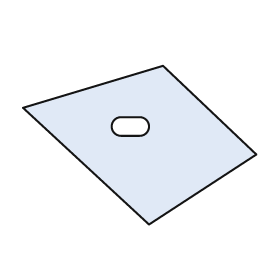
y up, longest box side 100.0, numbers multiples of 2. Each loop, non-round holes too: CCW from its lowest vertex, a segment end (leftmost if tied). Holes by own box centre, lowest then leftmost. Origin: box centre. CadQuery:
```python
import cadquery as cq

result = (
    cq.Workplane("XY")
    .moveTo(4.0, -34.0)
    .lineTo(50.0, -4.0)
    .lineTo(10.0, 34.0)
    .lineTo(-50.0, 16.0)
    .close()
    .moveTo(-8.0, 4.0)
    .lineTo(0.0, 4.0)
    .threePointArc((4.0, 8.0), (0.0, 12.0))
    .lineTo(-8.0, 12.0)
    .threePointArc((-12.0, 8.0), (-8.0, 4.0))
    .close()
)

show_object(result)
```